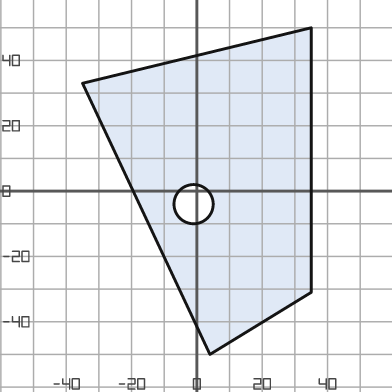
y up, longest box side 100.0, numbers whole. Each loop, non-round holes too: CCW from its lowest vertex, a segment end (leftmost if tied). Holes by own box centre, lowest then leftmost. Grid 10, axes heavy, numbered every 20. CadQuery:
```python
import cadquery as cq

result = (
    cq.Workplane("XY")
    .moveTo(4.0, -50.0)
    .lineTo(35.0, -31.0)
    .lineTo(35.0, 50.0)
    .lineTo(-35.0, 33.0)
    .close()
    .moveTo(-1.0, -4.0)
    .circle(6.0)
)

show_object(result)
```